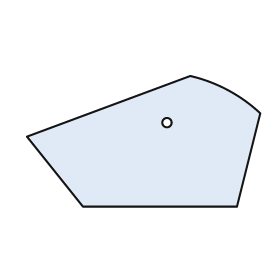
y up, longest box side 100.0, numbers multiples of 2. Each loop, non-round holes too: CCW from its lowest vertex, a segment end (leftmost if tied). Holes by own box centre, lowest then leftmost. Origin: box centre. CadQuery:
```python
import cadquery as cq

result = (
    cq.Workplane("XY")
    .moveTo(-26.0, -28.0)
    .lineTo(40.0, -28.0)
    .lineTo(50.0, 12.0)
    .threePointArc((36.0, 22.0), (20.0, 28.0))
    .lineTo(-50.0, 2.0)
    .close()
    .moveTo(10.0, 8.0)
    .circle(2.0)
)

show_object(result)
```